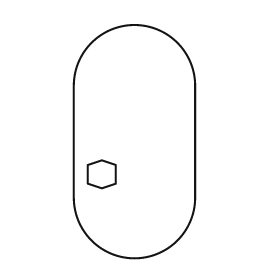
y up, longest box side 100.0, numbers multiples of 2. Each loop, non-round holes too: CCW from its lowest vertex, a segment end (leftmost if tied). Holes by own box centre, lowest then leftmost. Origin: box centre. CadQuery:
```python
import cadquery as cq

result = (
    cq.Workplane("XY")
    .moveTo(-26.0, -24.0)
    .threePointArc((0.0, -50.0), (26.0, -24.0))
    .lineTo(26.0, 24.0)
    .threePointArc((0.0, 50.0), (-26.0, 24.0))
    .close()
    .moveTo(-14.0, -20.0)
    .lineTo(-8.0, -18.0)
    .lineTo(-8.0, -10.0)
    .lineTo(-14.0, -8.0)
    .lineTo(-20.0, -10.0)
    .lineTo(-20.0, -18.0)
    .close()
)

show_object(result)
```